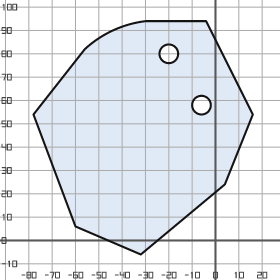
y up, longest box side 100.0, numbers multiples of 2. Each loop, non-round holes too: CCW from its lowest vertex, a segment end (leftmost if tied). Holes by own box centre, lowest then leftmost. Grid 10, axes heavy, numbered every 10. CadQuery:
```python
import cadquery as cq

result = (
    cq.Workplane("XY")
    .moveTo(-32.0, -6.0)
    .lineTo(4.0, 24.0)
    .lineTo(16.0, 54.0)
    .lineTo(-4.0, 94.0)
    .lineTo(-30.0, 94.0)
    .threePointArc((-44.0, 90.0), (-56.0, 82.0))
    .lineTo(-78.0, 54.0)
    .lineTo(-60.0, 6.0)
    .close()
    .moveTo(-6.0, 58.0)
    .circle(4.0)
    .moveTo(-20.0, 80.0)
    .circle(4.0)
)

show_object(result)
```